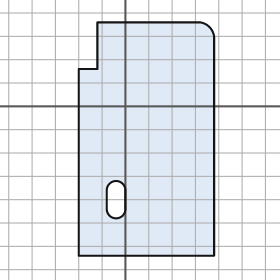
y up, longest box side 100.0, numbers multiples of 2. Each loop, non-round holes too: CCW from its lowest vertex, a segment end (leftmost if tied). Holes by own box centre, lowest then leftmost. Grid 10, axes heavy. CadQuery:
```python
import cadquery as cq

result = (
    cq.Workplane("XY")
    .moveTo(-20.0, -64.0)
    .lineTo(38.0, -64.0)
    .lineTo(38.0, 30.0)
    .threePointArc((36.0, 34.0), (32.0, 36.0))
    .lineTo(-12.0, 36.0)
    .lineTo(-12.0, 16.0)
    .lineTo(-20.0, 16.0)
    .close()
    .moveTo(-8.0, -44.0)
    .threePointArc((-4.0, -48.0), (0.0, -44.0))
    .lineTo(0.0, -36.0)
    .threePointArc((-4.0, -32.0), (-8.0, -36.0))
    .close()
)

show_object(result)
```